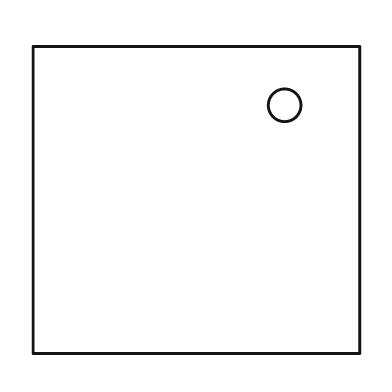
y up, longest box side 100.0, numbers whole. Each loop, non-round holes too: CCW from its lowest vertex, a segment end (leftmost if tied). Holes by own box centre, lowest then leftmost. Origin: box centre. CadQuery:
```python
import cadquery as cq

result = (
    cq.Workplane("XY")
    .moveTo(-50.0, -47.0)
    .lineTo(50.0, -47.0)
    .lineTo(50.0, 47.0)
    .lineTo(-50.0, 47.0)
    .close()
    .moveTo(27.0, 29.0)
    .circle(5.0)
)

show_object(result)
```